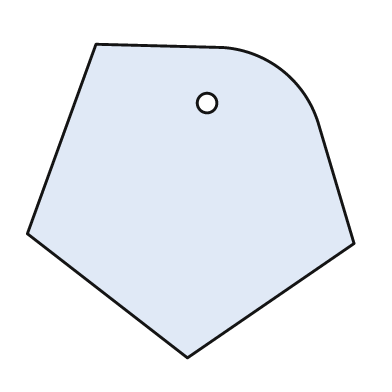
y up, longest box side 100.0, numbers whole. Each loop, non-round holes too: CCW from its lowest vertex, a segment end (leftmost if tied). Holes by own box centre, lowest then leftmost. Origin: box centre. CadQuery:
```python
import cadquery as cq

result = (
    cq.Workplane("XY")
    .moveTo(-1.0, -48.0)
    .lineTo(50.0, -13.0)
    .lineTo(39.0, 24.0)
    .threePointArc((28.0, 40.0), (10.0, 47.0))
    .lineTo(-29.0, 48.0)
    .lineTo(-50.0, -10.0)
    .close()
    .moveTo(5.0, 30.0)
    .circle(3.0)
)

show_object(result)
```